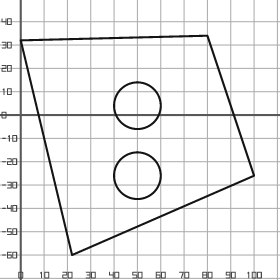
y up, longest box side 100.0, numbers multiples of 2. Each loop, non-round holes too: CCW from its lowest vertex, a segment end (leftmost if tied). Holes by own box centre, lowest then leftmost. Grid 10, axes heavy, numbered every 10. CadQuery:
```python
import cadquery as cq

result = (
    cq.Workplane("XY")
    .moveTo(22.0, -60.0)
    .lineTo(100.0, -26.0)
    .lineTo(80.0, 34.0)
    .lineTo(0.0, 32.0)
    .close()
    .moveTo(50.0, -26.0)
    .circle(10.0)
    .moveTo(50.0, 4.0)
    .circle(10.0)
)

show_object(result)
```